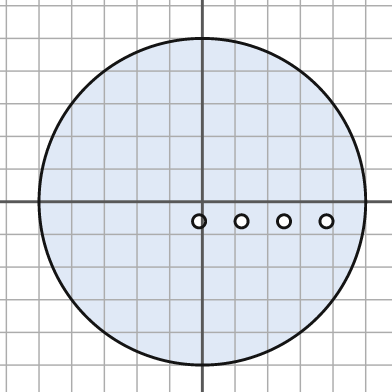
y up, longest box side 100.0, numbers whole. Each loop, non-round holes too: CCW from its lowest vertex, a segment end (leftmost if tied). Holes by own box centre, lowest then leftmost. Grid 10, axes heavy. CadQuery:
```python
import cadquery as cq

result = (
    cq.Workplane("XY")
    .moveTo(0.0, 0.0)
    .circle(50.0)
    .moveTo(-1.0, -6.0)
    .circle(2.0)
    .moveTo(12.0, -6.0)
    .circle(2.0)
    .moveTo(25.0, -6.0)
    .circle(2.0)
    .moveTo(38.0, -6.0)
    .circle(2.0)
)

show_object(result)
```